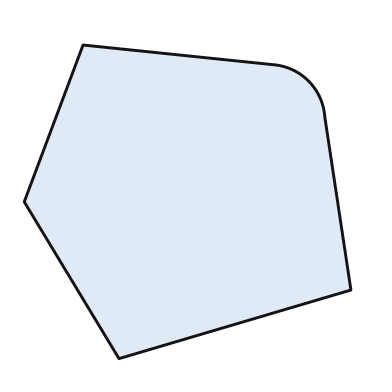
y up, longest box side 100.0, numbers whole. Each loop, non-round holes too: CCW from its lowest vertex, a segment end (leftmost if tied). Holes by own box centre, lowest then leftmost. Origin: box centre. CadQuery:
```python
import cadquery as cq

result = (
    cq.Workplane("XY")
    .moveTo(-21.0, -48.0)
    .lineTo(50.0, -27.0)
    .lineTo(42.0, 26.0)
    .threePointArc((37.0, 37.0), (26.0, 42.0))
    .lineTo(-32.0, 48.0)
    .lineTo(-50.0, 0.0)
    .close()
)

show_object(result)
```